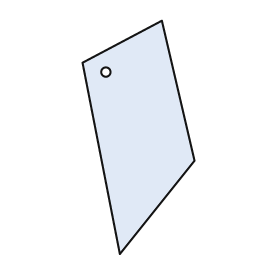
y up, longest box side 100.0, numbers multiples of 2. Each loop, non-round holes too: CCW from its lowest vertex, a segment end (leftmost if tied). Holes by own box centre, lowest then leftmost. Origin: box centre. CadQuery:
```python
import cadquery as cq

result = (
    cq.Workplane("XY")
    .moveTo(-8.0, -50.0)
    .lineTo(24.0, -10.0)
    .lineTo(10.0, 50.0)
    .lineTo(-24.0, 32.0)
    .close()
    .moveTo(-14.0, 28.0)
    .circle(2.0)
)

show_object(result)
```